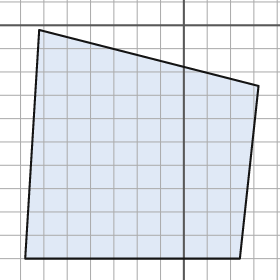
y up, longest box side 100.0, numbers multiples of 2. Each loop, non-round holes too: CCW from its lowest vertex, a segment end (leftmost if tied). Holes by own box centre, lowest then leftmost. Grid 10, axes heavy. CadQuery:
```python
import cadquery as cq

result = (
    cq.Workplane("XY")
    .moveTo(-68.0, -100.0)
    .lineTo(24.0, -100.0)
    .lineTo(32.0, -26.0)
    .lineTo(-62.0, -2.0)
    .close()
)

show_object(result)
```